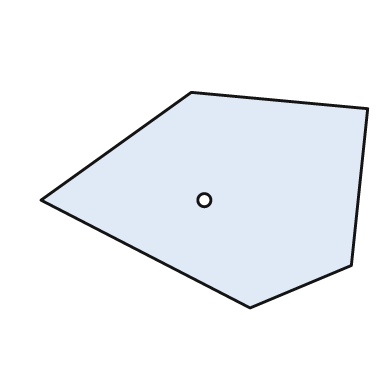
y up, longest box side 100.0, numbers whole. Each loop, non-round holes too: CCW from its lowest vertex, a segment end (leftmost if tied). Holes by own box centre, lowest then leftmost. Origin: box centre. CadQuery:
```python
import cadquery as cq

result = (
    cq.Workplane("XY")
    .moveTo(14.0, -33.0)
    .lineTo(45.0, -20.0)
    .lineTo(50.0, 28.0)
    .lineTo(-4.0, 33.0)
    .lineTo(-50.0, 0.0)
    .close()
    .moveTo(0.0, 0.0)
    .circle(2.0)
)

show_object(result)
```